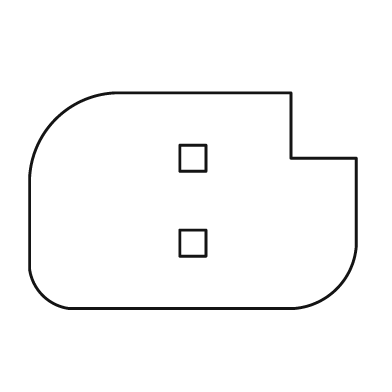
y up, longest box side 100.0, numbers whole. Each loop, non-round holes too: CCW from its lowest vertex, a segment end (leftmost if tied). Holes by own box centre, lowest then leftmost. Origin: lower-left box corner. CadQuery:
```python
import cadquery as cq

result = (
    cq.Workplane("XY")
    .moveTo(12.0, 0.0)
    .lineTo(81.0, 0.0)
    .threePointArc((94.0, 6.0), (100.0, 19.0))
    .lineTo(100.0, 46.0)
    .lineTo(80.0, 46.0)
    .lineTo(80.0, 66.0)
    .lineTo(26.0, 66.0)
    .threePointArc((8.0, 58.0), (0.0, 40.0))
    .lineTo(0.0, 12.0)
    .threePointArc((4.0, 4.0), (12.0, 0.0))
    .close()
    .moveTo(46.0, 16.0)
    .lineTo(54.0, 16.0)
    .lineTo(54.0, 24.0)
    .lineTo(46.0, 24.0)
    .close()
    .moveTo(46.0, 42.0)
    .lineTo(54.0, 42.0)
    .lineTo(54.0, 50.0)
    .lineTo(46.0, 50.0)
    .close()
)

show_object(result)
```